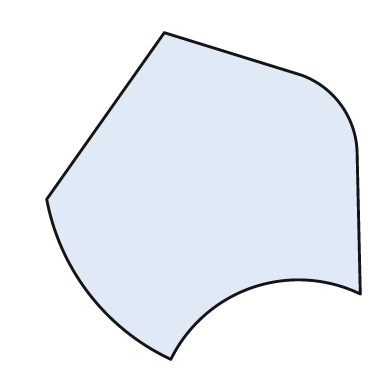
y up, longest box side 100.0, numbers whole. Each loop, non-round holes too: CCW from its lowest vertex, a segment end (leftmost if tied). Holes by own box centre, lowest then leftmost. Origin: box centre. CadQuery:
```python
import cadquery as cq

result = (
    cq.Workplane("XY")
    .moveTo(-10.0, -50.0)
    .threePointArc((15.0, -28.0), (48.0, -30.0))
    .lineTo(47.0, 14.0)
    .threePointArc((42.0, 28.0), (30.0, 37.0))
    .lineTo(-12.0, 50.0)
    .lineTo(-48.0, -1.0)
    .threePointArc((-35.0, -30.0), (-10.0, -50.0))
    .close()
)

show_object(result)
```